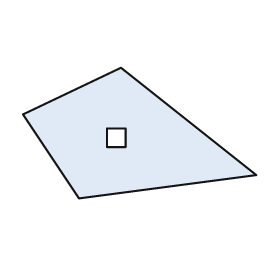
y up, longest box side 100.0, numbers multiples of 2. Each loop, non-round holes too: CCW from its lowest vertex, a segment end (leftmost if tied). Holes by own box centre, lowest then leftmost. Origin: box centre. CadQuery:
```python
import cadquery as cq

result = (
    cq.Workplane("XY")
    .moveTo(-26.0, -28.0)
    .lineTo(50.0, -18.0)
    .lineTo(-8.0, 28.0)
    .lineTo(-50.0, 8.0)
    .close()
    .moveTo(-14.0, -6.0)
    .lineTo(-6.0, -6.0)
    .lineTo(-6.0, 2.0)
    .lineTo(-14.0, 2.0)
    .close()
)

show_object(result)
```